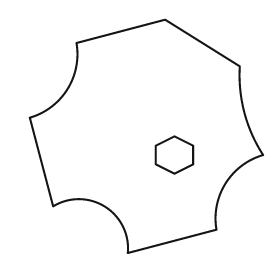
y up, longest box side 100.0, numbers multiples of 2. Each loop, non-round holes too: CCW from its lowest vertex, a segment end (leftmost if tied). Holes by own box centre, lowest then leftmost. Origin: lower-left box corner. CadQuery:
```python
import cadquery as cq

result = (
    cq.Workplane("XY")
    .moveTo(42.0, 0.0)
    .lineTo(80.0, 10.0)
    .threePointArc((84.0, 30.0), (100.0, 42.0))
    .threePointArc((92.0, 60.0), (90.0, 80.0))
    .lineTo(58.0, 100.0)
    .lineTo(20.0, 90.0)
    .threePointArc((16.0, 70.0), (0.0, 58.0))
    .lineTo(10.0, 20.0)
    .threePointArc((32.0, 20.0), (42.0, 0.0))
    .close()
    .moveTo(62.0, 34.0)
    .lineTo(70.0, 38.0)
    .lineTo(70.0, 46.0)
    .lineTo(62.0, 50.0)
    .lineTo(54.0, 46.0)
    .lineTo(54.0, 38.0)
    .close()
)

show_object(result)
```